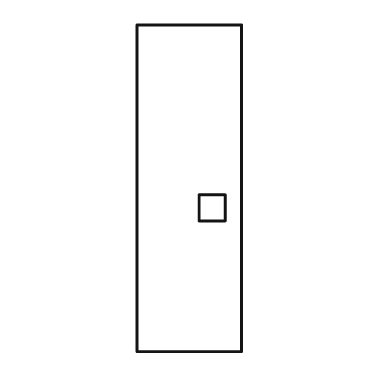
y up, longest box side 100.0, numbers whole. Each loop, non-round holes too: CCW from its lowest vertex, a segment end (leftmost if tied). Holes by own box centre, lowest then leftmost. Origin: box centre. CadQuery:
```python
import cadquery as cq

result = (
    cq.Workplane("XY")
    .moveTo(-16.0, -50.0)
    .lineTo(16.0, -50.0)
    .lineTo(16.0, 50.0)
    .lineTo(-16.0, 50.0)
    .close()
    .moveTo(3.0, -10.0)
    .lineTo(11.0, -10.0)
    .lineTo(11.0, -2.0)
    .lineTo(3.0, -2.0)
    .close()
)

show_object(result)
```